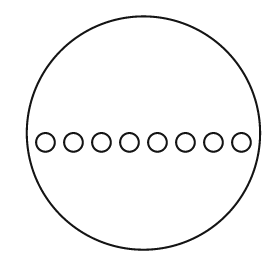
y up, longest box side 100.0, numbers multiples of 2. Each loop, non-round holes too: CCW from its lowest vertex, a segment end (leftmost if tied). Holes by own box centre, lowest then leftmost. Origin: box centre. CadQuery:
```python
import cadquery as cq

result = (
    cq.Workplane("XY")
    .moveTo(0.0, 0.0)
    .circle(50.0)
    .moveTo(-42.0, -4.0)
    .circle(4.0)
    .moveTo(-30.0, -4.0)
    .circle(4.0)
    .moveTo(-18.0, -4.0)
    .circle(4.0)
    .moveTo(-6.0, -4.0)
    .circle(4.0)
    .moveTo(6.0, -4.0)
    .circle(4.0)
    .moveTo(18.0, -4.0)
    .circle(4.0)
    .moveTo(30.0, -4.0)
    .circle(4.0)
    .moveTo(42.0, -4.0)
    .circle(4.0)
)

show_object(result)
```